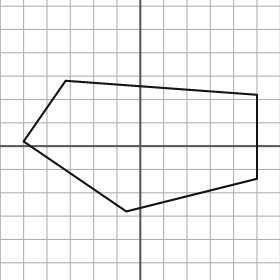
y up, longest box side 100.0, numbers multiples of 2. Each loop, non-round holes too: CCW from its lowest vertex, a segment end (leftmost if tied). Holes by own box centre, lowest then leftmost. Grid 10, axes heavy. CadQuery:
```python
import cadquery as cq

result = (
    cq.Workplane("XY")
    .moveTo(-6.0, -28.0)
    .lineTo(50.0, -14.0)
    .lineTo(50.0, 22.0)
    .lineTo(-32.0, 28.0)
    .lineTo(-50.0, 2.0)
    .close()
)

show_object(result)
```